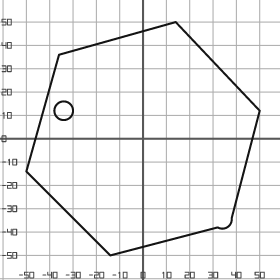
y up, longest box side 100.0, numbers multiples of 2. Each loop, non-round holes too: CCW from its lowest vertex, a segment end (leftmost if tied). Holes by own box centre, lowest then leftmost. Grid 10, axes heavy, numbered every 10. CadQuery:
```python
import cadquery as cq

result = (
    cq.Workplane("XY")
    .moveTo(-14.0, -50.0)
    .lineTo(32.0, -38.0)
    .threePointArc((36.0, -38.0), (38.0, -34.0))
    .lineTo(50.0, 12.0)
    .lineTo(14.0, 50.0)
    .lineTo(-36.0, 36.0)
    .lineTo(-50.0, -14.0)
    .close()
    .moveTo(-34.0, 12.0)
    .circle(4.0)
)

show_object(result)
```